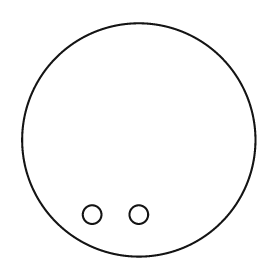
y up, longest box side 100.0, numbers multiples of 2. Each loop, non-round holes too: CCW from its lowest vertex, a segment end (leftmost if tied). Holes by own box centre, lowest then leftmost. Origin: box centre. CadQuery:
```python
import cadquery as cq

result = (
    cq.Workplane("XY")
    .moveTo(0.0, 0.0)
    .circle(50.0)
    .moveTo(-20.0, -32.0)
    .circle(4.0)
    .moveTo(0.0, -32.0)
    .circle(4.0)
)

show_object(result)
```